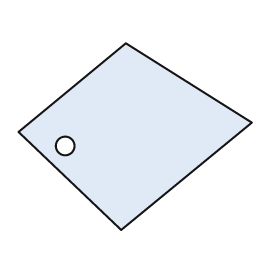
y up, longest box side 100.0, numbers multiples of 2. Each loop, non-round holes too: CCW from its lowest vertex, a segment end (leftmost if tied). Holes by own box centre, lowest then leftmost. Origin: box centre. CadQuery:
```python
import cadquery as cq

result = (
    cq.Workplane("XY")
    .moveTo(-6.0, -40.0)
    .lineTo(50.0, 6.0)
    .lineTo(-4.0, 40.0)
    .lineTo(-50.0, 2.0)
    .close()
    .moveTo(-30.0, -4.0)
    .circle(4.0)
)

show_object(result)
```